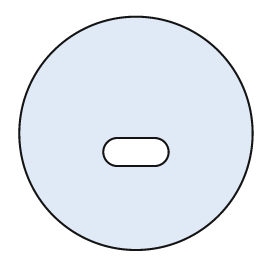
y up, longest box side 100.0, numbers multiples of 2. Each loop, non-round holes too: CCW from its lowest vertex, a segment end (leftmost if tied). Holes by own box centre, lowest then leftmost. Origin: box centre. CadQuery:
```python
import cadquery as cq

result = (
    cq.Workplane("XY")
    .moveTo(0.0, 0.0)
    .circle(50.0)
    .moveTo(-8.0, -14.0)
    .lineTo(8.0, -14.0)
    .threePointArc((14.0, -8.0), (8.0, -2.0))
    .lineTo(-8.0, -2.0)
    .threePointArc((-14.0, -8.0), (-8.0, -14.0))
    .close()
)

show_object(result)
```